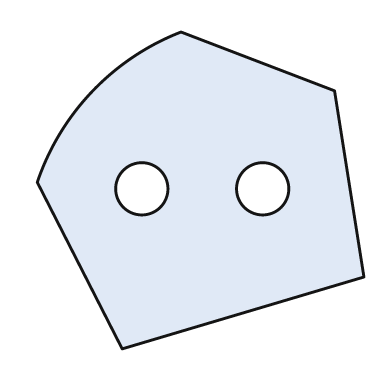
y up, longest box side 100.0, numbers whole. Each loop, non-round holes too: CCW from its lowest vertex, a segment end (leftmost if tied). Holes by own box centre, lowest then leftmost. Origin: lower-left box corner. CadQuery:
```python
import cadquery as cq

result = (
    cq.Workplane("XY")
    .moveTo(26.0, 0.0)
    .lineTo(100.0, 22.0)
    .lineTo(91.0, 79.0)
    .lineTo(44.0, 97.0)
    .threePointArc((17.0, 79.0), (0.0, 51.0))
    .close()
    .moveTo(32.0, 49.0)
    .circle(8.0)
    .moveTo(69.0, 49.0)
    .circle(8.0)
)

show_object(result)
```